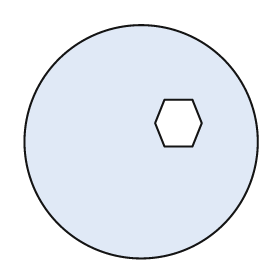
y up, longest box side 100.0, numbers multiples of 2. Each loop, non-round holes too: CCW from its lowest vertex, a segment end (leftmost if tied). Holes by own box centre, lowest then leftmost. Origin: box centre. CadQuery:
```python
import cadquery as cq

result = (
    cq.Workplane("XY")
    .moveTo(0.0, 0.0)
    .circle(50.0)
    .moveTo(10.0, -2.0)
    .lineTo(22.0, -2.0)
    .lineTo(26.0, 8.0)
    .lineTo(22.0, 18.0)
    .lineTo(10.0, 18.0)
    .lineTo(6.0, 8.0)
    .close()
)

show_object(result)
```